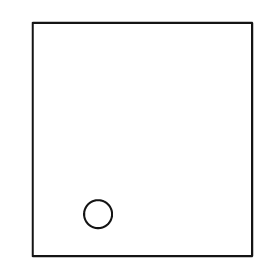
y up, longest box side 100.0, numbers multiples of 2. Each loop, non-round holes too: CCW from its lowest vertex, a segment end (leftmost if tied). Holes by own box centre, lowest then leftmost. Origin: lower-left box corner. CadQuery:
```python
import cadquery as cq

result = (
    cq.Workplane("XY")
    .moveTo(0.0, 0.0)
    .lineTo(94.0, 0.0)
    .lineTo(94.0, 100.0)
    .lineTo(0.0, 100.0)
    .close()
    .moveTo(28.0, 18.0)
    .circle(6.0)
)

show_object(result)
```